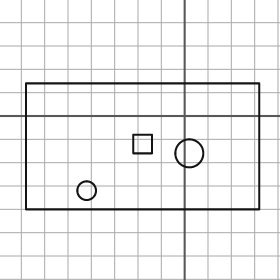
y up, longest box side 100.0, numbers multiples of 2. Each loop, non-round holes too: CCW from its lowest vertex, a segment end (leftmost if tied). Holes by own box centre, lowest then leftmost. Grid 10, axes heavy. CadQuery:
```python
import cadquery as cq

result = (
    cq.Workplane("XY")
    .moveTo(-68.0, -40.0)
    .lineTo(32.0, -40.0)
    .lineTo(32.0, 14.0)
    .lineTo(-68.0, 14.0)
    .close()
    .moveTo(-42.0, -32.0)
    .circle(4.0)
    .moveTo(2.0, -16.0)
    .circle(6.0)
    .moveTo(-22.0, -16.0)
    .lineTo(-14.0, -16.0)
    .lineTo(-14.0, -8.0)
    .lineTo(-22.0, -8.0)
    .close()
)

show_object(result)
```